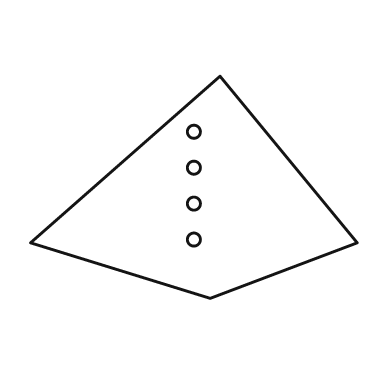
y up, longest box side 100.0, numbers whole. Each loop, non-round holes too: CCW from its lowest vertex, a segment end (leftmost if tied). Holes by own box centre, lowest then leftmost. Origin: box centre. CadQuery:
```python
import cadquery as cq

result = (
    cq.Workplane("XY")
    .moveTo(5.0, -34.0)
    .lineTo(50.0, -17.0)
    .lineTo(8.0, 34.0)
    .lineTo(-50.0, -17.0)
    .close()
    .moveTo(0.0, -16.0)
    .circle(2.0)
    .moveTo(0.0, -5.0)
    .circle(2.0)
    .moveTo(0.0, 6.0)
    .circle(2.0)
    .moveTo(0.0, 17.0)
    .circle(2.0)
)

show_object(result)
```